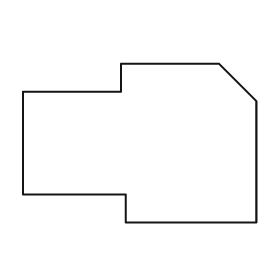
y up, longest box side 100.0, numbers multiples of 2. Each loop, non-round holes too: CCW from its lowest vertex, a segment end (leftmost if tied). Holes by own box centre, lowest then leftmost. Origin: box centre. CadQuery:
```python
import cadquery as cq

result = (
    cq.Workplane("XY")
    .moveTo(-6.0, -34.0)
    .lineTo(50.0, -34.0)
    .lineTo(50.0, 18.0)
    .lineTo(34.0, 34.0)
    .lineTo(-8.0, 34.0)
    .lineTo(-8.0, 22.0)
    .lineTo(-50.0, 22.0)
    .lineTo(-50.0, -22.0)
    .lineTo(-6.0, -22.0)
    .close()
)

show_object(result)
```